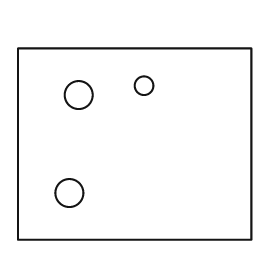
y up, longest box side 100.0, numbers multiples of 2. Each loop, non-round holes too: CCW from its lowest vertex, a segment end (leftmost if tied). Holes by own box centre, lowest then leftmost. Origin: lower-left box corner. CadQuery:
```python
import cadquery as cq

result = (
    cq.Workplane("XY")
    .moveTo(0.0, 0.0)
    .lineTo(100.0, 0.0)
    .lineTo(100.0, 82.0)
    .lineTo(0.0, 82.0)
    .close()
    .moveTo(22.0, 20.0)
    .circle(6.0)
    .moveTo(26.0, 62.0)
    .circle(6.0)
    .moveTo(54.0, 66.0)
    .circle(4.0)
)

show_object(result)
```